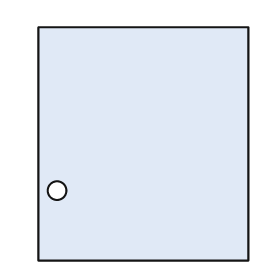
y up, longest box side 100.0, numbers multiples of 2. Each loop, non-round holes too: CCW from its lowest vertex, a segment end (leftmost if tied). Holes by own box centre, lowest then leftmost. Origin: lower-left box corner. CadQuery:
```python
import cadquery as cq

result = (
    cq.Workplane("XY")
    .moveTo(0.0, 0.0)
    .lineTo(90.0, 0.0)
    .lineTo(90.0, 100.0)
    .lineTo(0.0, 100.0)
    .close()
    .moveTo(8.0, 30.0)
    .circle(4.0)
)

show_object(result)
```